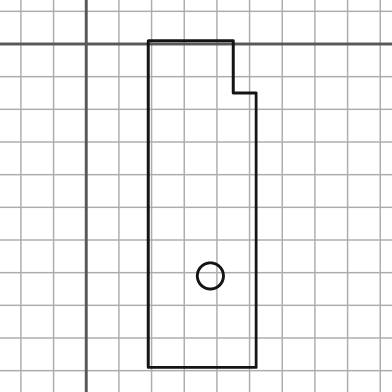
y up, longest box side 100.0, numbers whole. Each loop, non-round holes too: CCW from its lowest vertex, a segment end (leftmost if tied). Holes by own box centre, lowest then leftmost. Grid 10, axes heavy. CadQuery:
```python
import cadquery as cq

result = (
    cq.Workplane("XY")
    .moveTo(19.0, -99.0)
    .lineTo(52.0, -99.0)
    .lineTo(52.0, -15.0)
    .lineTo(45.0, -15.0)
    .lineTo(45.0, 1.0)
    .lineTo(19.0, 1.0)
    .close()
    .moveTo(38.0, -71.0)
    .circle(4.0)
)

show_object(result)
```